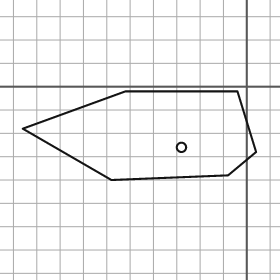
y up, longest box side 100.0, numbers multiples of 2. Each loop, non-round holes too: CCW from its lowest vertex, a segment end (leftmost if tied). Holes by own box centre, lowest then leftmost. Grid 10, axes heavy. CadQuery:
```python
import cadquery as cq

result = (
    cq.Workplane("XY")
    .moveTo(-58.0, -40.0)
    .lineTo(-8.0, -38.0)
    .lineTo(4.0, -28.0)
    .lineTo(-4.0, -2.0)
    .lineTo(-52.0, -2.0)
    .lineTo(-96.0, -18.0)
    .close()
    .moveTo(-28.0, -26.0)
    .circle(2.0)
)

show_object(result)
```